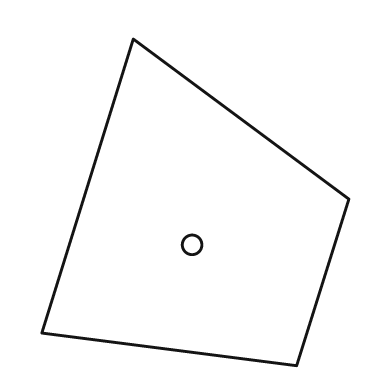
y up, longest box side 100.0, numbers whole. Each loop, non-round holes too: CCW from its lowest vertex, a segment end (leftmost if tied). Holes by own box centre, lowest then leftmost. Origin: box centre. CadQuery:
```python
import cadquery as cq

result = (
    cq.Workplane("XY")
    .moveTo(31.0, -50.0)
    .lineTo(47.0, 1.0)
    .lineTo(-19.0, 50.0)
    .lineTo(-47.0, -40.0)
    .close()
    .moveTo(-1.0, -13.0)
    .circle(3.0)
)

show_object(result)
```